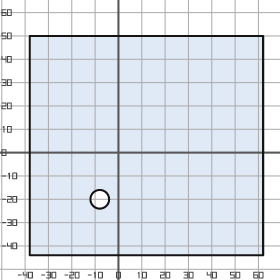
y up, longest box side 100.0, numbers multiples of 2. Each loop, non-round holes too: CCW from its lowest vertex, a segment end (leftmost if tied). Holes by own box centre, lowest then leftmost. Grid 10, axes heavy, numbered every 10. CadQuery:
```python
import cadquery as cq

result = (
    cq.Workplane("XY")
    .moveTo(-38.0, -44.0)
    .lineTo(62.0, -44.0)
    .lineTo(62.0, 50.0)
    .lineTo(-38.0, 50.0)
    .close()
    .moveTo(-8.0, -20.0)
    .circle(4.0)
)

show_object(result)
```